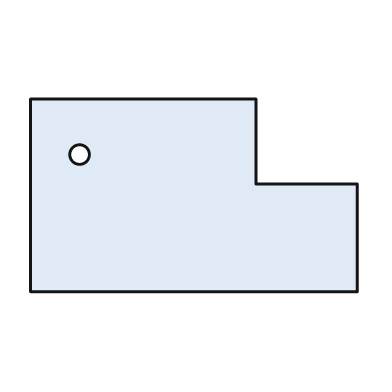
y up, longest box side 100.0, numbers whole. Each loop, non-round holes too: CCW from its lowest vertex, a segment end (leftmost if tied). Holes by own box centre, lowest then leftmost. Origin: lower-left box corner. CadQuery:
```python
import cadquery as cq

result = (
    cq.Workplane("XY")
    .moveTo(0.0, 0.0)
    .lineTo(100.0, 0.0)
    .lineTo(100.0, 33.0)
    .lineTo(69.0, 33.0)
    .lineTo(69.0, 59.0)
    .lineTo(0.0, 59.0)
    .close()
    .moveTo(15.0, 42.0)
    .circle(3.0)
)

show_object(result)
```